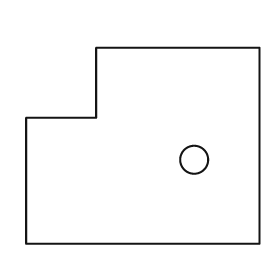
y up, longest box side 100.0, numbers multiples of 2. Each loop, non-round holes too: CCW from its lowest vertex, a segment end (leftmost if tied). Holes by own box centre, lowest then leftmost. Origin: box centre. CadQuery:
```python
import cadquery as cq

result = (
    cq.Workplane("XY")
    .moveTo(-50.0, -42.0)
    .lineTo(50.0, -42.0)
    .lineTo(50.0, 42.0)
    .lineTo(-20.0, 42.0)
    .lineTo(-20.0, 12.0)
    .lineTo(-50.0, 12.0)
    .close()
    .moveTo(22.0, -6.0)
    .circle(6.0)
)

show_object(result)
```